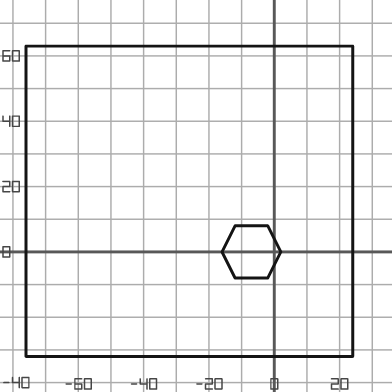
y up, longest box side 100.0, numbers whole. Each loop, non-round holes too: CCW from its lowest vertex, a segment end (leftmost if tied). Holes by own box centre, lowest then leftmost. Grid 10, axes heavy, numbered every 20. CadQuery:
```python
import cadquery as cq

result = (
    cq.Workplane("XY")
    .moveTo(-76.0, -32.0)
    .lineTo(24.0, -32.0)
    .lineTo(24.0, 63.0)
    .lineTo(-76.0, 63.0)
    .close()
    .moveTo(-12.0, -8.0)
    .lineTo(-2.0, -8.0)
    .lineTo(2.0, 0.0)
    .lineTo(-2.0, 8.0)
    .lineTo(-12.0, 8.0)
    .lineTo(-16.0, 0.0)
    .close()
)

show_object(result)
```